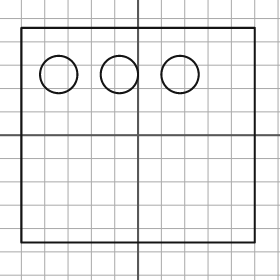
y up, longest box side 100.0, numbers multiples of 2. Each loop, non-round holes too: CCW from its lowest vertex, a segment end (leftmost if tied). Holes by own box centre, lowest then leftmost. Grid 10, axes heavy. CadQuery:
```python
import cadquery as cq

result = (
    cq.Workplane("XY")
    .moveTo(-50.0, -46.0)
    .lineTo(50.0, -46.0)
    .lineTo(50.0, 46.0)
    .lineTo(-50.0, 46.0)
    .close()
    .moveTo(-34.0, 26.0)
    .circle(8.0)
    .moveTo(-8.0, 26.0)
    .circle(8.0)
    .moveTo(18.0, 26.0)
    .circle(8.0)
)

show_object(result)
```